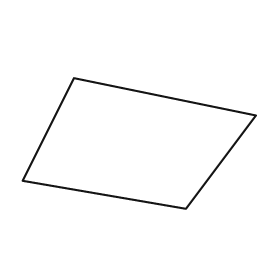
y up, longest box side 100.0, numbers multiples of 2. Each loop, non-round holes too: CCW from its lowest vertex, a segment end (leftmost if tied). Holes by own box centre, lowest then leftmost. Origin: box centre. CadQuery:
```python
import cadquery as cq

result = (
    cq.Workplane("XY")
    .moveTo(20.0, -28.0)
    .lineTo(50.0, 12.0)
    .lineTo(-28.0, 28.0)
    .lineTo(-50.0, -16.0)
    .close()
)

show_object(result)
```